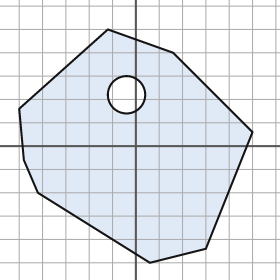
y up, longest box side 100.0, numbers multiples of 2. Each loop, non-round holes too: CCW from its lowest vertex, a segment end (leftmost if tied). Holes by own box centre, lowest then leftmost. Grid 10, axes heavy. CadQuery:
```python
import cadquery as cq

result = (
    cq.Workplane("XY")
    .moveTo(6.0, -50.0)
    .lineTo(30.0, -44.0)
    .lineTo(50.0, 6.0)
    .lineTo(16.0, 40.0)
    .lineTo(-12.0, 50.0)
    .lineTo(-50.0, 16.0)
    .lineTo(-48.0, -6.0)
    .lineTo(-42.0, -20.0)
    .close()
    .moveTo(-4.0, 22.0)
    .circle(8.0)
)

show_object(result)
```